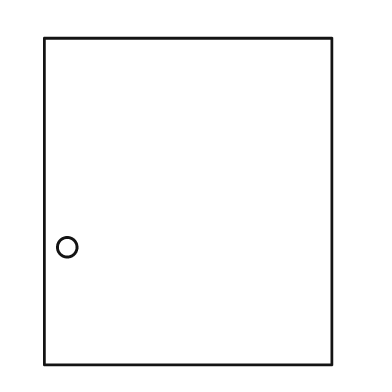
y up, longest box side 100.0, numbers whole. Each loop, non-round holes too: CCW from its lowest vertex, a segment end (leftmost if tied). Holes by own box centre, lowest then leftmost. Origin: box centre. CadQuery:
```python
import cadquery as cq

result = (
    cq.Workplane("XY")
    .moveTo(-44.0, -50.0)
    .lineTo(44.0, -50.0)
    .lineTo(44.0, 50.0)
    .lineTo(-44.0, 50.0)
    .close()
    .moveTo(-37.0, -14.0)
    .circle(3.0)
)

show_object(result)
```